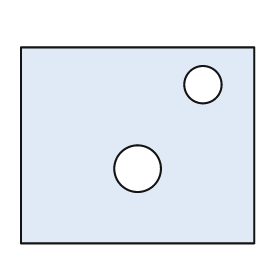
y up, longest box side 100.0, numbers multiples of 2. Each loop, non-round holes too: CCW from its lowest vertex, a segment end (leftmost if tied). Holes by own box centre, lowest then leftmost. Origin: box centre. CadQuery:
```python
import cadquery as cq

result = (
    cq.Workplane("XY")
    .moveTo(-50.0, -42.0)
    .lineTo(50.0, -42.0)
    .lineTo(50.0, 42.0)
    .lineTo(-50.0, 42.0)
    .close()
    .moveTo(0.0, -10.0)
    .circle(10.0)
    .moveTo(28.0, 26.0)
    .circle(8.0)
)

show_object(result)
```